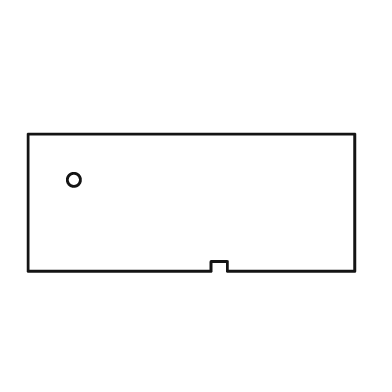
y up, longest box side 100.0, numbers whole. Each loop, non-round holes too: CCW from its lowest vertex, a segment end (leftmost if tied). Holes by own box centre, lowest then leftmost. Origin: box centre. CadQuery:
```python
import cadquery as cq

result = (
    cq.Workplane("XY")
    .moveTo(-50.0, -21.0)
    .lineTo(6.0, -21.0)
    .lineTo(6.0, -18.0)
    .lineTo(11.0, -18.0)
    .lineTo(11.0, -21.0)
    .lineTo(50.0, -21.0)
    .lineTo(50.0, 21.0)
    .lineTo(-50.0, 21.0)
    .close()
    .moveTo(-36.0, 7.0)
    .circle(2.0)
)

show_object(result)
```